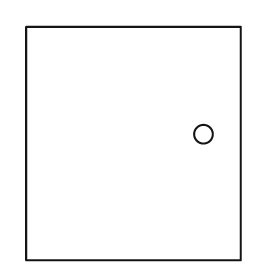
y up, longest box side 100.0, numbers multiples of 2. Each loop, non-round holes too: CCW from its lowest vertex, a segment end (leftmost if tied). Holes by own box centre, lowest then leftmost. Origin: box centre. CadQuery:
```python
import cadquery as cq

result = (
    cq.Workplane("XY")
    .moveTo(-46.0, -50.0)
    .lineTo(46.0, -50.0)
    .lineTo(46.0, 50.0)
    .lineTo(-46.0, 50.0)
    .close()
    .moveTo(30.0, 4.0)
    .circle(4.0)
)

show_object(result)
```